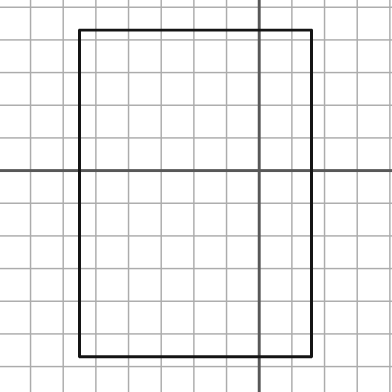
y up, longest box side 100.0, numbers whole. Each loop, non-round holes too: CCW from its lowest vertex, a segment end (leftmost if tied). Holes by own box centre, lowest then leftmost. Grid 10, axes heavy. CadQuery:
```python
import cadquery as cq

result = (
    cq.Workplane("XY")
    .moveTo(-55.0, -57.0)
    .lineTo(16.0, -57.0)
    .lineTo(16.0, 43.0)
    .lineTo(-55.0, 43.0)
    .close()
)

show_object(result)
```